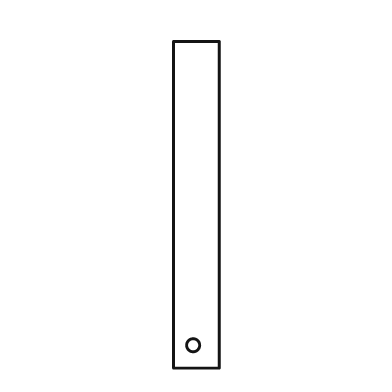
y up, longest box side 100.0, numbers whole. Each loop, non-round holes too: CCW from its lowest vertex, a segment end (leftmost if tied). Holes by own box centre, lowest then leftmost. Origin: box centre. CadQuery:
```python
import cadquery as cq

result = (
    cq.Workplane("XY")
    .moveTo(-7.0, -50.0)
    .lineTo(7.0, -50.0)
    .lineTo(7.0, 50.0)
    .lineTo(-7.0, 50.0)
    .close()
    .moveTo(-1.0, -43.0)
    .circle(2.0)
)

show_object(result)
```